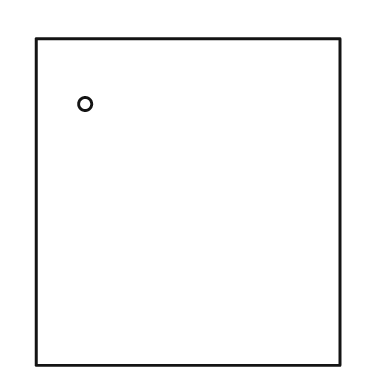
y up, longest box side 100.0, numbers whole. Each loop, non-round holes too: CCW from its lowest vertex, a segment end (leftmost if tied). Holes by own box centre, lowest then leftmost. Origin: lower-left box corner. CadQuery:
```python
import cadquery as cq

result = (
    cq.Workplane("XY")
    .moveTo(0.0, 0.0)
    .lineTo(93.0, 0.0)
    .lineTo(93.0, 100.0)
    .lineTo(0.0, 100.0)
    .close()
    .moveTo(15.0, 80.0)
    .circle(2.0)
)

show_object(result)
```